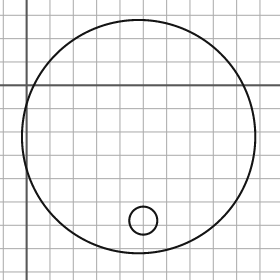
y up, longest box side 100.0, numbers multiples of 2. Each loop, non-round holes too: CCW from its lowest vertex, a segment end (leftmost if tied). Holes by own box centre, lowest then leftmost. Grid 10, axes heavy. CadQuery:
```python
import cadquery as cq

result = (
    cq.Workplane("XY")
    .moveTo(48.0, -22.0)
    .circle(50.0)
    .moveTo(50.0, -58.0)
    .circle(6.0)
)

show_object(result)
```